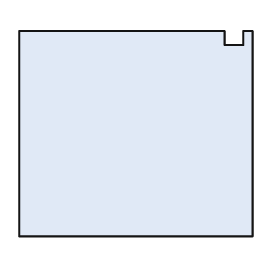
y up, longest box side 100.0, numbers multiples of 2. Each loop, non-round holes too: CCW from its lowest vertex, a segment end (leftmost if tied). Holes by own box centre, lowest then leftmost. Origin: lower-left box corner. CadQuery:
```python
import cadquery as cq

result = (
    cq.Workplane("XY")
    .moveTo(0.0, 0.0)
    .lineTo(100.0, 0.0)
    .lineTo(100.0, 88.0)
    .lineTo(96.0, 88.0)
    .lineTo(96.0, 82.0)
    .lineTo(88.0, 82.0)
    .lineTo(88.0, 88.0)
    .lineTo(0.0, 88.0)
    .close()
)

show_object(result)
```